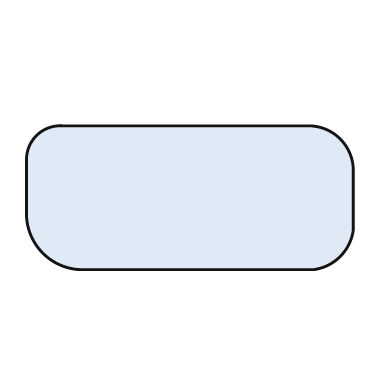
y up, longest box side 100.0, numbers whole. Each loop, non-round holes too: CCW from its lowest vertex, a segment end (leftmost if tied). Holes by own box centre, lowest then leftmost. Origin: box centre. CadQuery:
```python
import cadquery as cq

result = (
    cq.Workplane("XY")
    .moveTo(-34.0, -22.0)
    .lineTo(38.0, -22.0)
    .threePointArc((46.0, -18.0), (50.0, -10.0))
    .lineTo(50.0, 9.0)
    .threePointArc((46.0, 18.0), (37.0, 22.0))
    .lineTo(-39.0, 22.0)
    .threePointArc((-47.0, 19.0), (-50.0, 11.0))
    .lineTo(-50.0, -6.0)
    .threePointArc((-45.0, -17.0), (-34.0, -22.0))
    .close()
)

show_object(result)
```